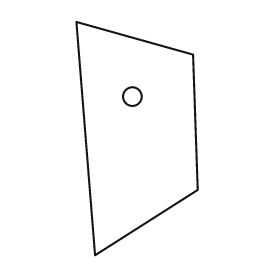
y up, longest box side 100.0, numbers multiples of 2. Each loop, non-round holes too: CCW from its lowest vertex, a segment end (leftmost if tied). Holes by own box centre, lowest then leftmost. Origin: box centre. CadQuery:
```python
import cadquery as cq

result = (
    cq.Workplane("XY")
    .moveTo(-18.0, -50.0)
    .lineTo(26.0, -22.0)
    .lineTo(24.0, 36.0)
    .lineTo(-26.0, 50.0)
    .close()
    .moveTo(-2.0, 18.0)
    .circle(4.0)
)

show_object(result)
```